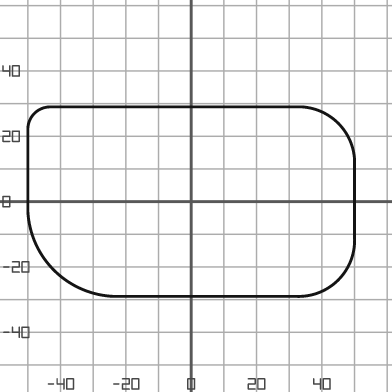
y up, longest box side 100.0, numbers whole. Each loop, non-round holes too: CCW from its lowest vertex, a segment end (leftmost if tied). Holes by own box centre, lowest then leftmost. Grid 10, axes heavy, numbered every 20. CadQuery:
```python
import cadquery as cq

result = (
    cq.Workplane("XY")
    .moveTo(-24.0, -29.0)
    .lineTo(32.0, -29.0)
    .threePointArc((45.0, -24.0), (50.0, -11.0))
    .lineTo(50.0, 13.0)
    .threePointArc((45.0, 24.0), (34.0, 29.0))
    .lineTo(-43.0, 29.0)
    .threePointArc((-48.0, 27.0), (-50.0, 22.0))
    .lineTo(-50.0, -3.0)
    .threePointArc((-42.0, -21.0), (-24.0, -29.0))
    .close()
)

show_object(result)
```